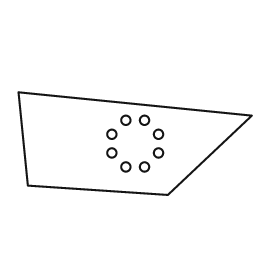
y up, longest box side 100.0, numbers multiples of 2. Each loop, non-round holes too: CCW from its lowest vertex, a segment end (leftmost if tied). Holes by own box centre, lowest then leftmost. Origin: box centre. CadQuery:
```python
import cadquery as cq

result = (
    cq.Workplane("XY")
    .moveTo(14.0, -22.0)
    .lineTo(50.0, 12.0)
    .lineTo(-50.0, 22.0)
    .lineTo(-46.0, -18.0)
    .close()
    .moveTo(-4.0, -10.0)
    .circle(2.0)
    .moveTo(4.0, -10.0)
    .circle(2.0)
    .moveTo(-10.0, -4.0)
    .circle(2.0)
    .moveTo(10.0, -4.0)
    .circle(2.0)
    .moveTo(-10.0, 4.0)
    .circle(2.0)
    .moveTo(10.0, 4.0)
    .circle(2.0)
    .moveTo(-4.0, 10.0)
    .circle(2.0)
    .moveTo(4.0, 10.0)
    .circle(2.0)
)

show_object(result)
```